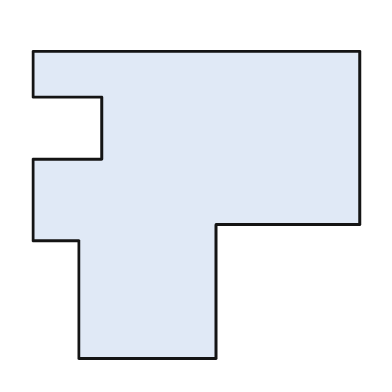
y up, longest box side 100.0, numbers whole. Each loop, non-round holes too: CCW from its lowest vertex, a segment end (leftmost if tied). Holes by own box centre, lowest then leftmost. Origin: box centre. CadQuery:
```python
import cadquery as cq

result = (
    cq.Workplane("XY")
    .moveTo(-36.0, -47.0)
    .lineTo(6.0, -47.0)
    .lineTo(6.0, -6.0)
    .lineTo(50.0, -6.0)
    .lineTo(50.0, 47.0)
    .lineTo(-50.0, 47.0)
    .lineTo(-50.0, 33.0)
    .lineTo(-29.0, 33.0)
    .lineTo(-29.0, 14.0)
    .lineTo(-50.0, 14.0)
    .lineTo(-50.0, -11.0)
    .lineTo(-36.0, -11.0)
    .close()
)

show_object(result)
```